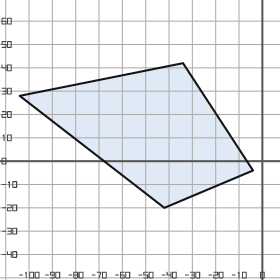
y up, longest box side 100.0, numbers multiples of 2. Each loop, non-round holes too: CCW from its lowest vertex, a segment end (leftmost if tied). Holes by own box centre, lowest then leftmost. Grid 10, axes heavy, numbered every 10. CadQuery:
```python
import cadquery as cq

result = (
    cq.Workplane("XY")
    .moveTo(-42.0, -20.0)
    .lineTo(-4.0, -4.0)
    .lineTo(-34.0, 42.0)
    .lineTo(-104.0, 28.0)
    .close()
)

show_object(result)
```